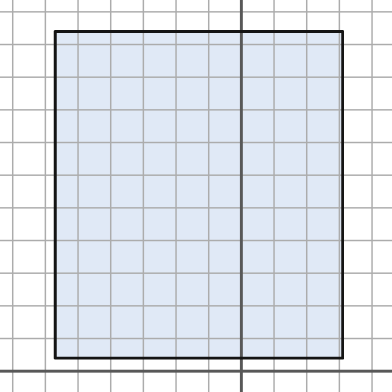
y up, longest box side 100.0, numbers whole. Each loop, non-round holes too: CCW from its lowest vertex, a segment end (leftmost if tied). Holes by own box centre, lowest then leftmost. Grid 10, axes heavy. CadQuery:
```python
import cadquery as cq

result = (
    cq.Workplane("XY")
    .moveTo(-57.0, 4.0)
    .lineTo(31.0, 4.0)
    .lineTo(31.0, 104.0)
    .lineTo(-57.0, 104.0)
    .close()
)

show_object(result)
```